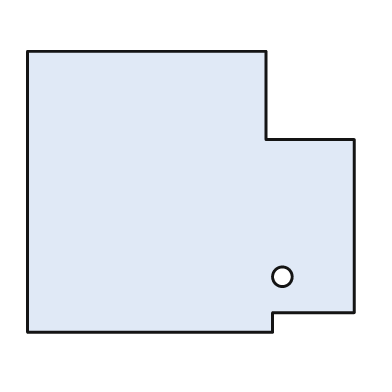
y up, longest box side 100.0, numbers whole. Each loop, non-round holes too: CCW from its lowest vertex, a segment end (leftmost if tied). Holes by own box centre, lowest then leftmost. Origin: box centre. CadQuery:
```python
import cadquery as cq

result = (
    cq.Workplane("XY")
    .moveTo(-50.0, -43.0)
    .lineTo(25.0, -43.0)
    .lineTo(25.0, -37.0)
    .lineTo(50.0, -37.0)
    .lineTo(50.0, 16.0)
    .lineTo(23.0, 16.0)
    .lineTo(23.0, 43.0)
    .lineTo(-50.0, 43.0)
    .close()
    .moveTo(28.0, -26.0)
    .circle(3.0)
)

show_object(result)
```